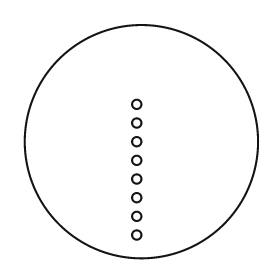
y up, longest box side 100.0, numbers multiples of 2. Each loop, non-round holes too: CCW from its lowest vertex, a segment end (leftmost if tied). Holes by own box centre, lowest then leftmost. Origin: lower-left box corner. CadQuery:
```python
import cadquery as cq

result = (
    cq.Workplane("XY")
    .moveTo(50.0, 50.0)
    .circle(50.0)
    .moveTo(48.0, 10.0)
    .circle(2.0)
    .moveTo(48.0, 18.0)
    .circle(2.0)
    .moveTo(48.0, 26.0)
    .circle(2.0)
    .moveTo(48.0, 34.0)
    .circle(2.0)
    .moveTo(48.0, 42.0)
    .circle(2.0)
    .moveTo(48.0, 50.0)
    .circle(2.0)
    .moveTo(48.0, 58.0)
    .circle(2.0)
    .moveTo(48.0, 66.0)
    .circle(2.0)
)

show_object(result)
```